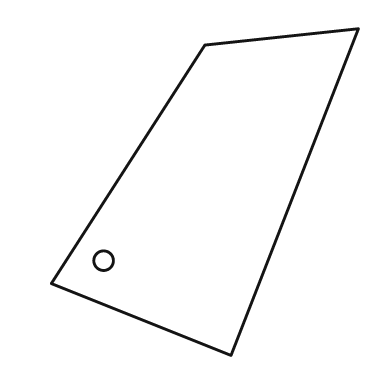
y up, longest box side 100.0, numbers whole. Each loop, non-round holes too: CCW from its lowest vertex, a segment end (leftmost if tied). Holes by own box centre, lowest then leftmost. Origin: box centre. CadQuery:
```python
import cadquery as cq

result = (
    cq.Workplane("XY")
    .moveTo(8.0, -50.0)
    .lineTo(47.0, 50.0)
    .lineTo(0.0, 45.0)
    .lineTo(-47.0, -28.0)
    .close()
    .moveTo(-31.0, -21.0)
    .circle(3.0)
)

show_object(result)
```